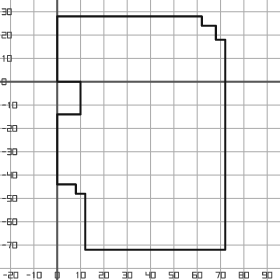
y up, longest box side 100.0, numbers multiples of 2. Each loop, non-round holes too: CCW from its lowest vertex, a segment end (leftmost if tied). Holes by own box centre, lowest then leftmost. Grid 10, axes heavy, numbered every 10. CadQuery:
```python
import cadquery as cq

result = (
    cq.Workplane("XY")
    .moveTo(12.0, -72.0)
    .lineTo(72.0, -72.0)
    .lineTo(72.0, 18.0)
    .lineTo(68.0, 18.0)
    .lineTo(68.0, 24.0)
    .lineTo(62.0, 24.0)
    .lineTo(62.0, 28.0)
    .lineTo(0.0, 28.0)
    .lineTo(0.0, 0.0)
    .lineTo(10.0, 0.0)
    .lineTo(10.0, -14.0)
    .lineTo(0.0, -14.0)
    .lineTo(0.0, -44.0)
    .lineTo(8.0, -44.0)
    .lineTo(8.0, -48.0)
    .lineTo(12.0, -48.0)
    .close()
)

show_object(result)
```